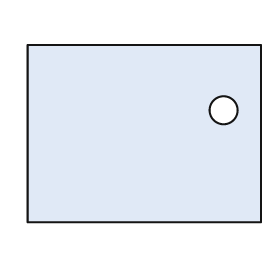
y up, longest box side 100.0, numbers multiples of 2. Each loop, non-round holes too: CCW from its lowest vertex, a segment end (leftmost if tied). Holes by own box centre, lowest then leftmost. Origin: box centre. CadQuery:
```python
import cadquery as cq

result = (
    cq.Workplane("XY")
    .moveTo(-50.0, -38.0)
    .lineTo(50.0, -38.0)
    .lineTo(50.0, 38.0)
    .lineTo(-50.0, 38.0)
    .close()
    .moveTo(34.0, 10.0)
    .circle(6.0)
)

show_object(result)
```